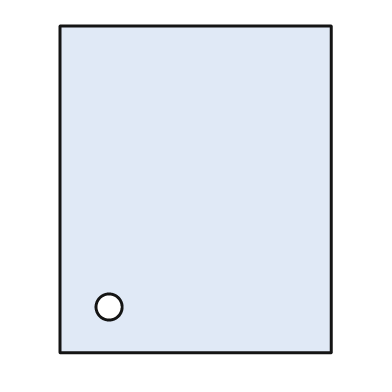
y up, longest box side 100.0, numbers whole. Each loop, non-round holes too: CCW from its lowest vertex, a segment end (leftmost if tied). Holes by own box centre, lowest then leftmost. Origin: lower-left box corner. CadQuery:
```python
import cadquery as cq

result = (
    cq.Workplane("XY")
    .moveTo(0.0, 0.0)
    .lineTo(83.0, 0.0)
    .lineTo(83.0, 100.0)
    .lineTo(0.0, 100.0)
    .close()
    .moveTo(15.0, 14.0)
    .circle(4.0)
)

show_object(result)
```